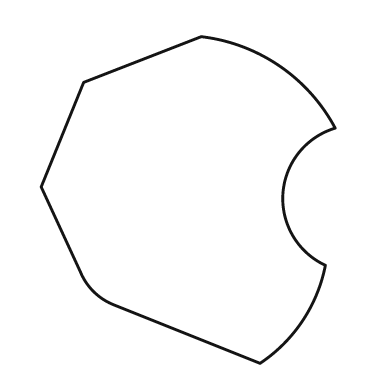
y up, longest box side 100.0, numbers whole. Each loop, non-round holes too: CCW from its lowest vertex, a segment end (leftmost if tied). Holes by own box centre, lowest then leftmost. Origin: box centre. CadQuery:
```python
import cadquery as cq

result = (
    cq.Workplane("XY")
    .moveTo(22.0, -50.0)
    .threePointArc((35.0, -37.0), (42.0, -20.0))
    .threePointArc((29.0, 2.0), (45.0, 22.0))
    .threePointArc((28.0, 41.0), (4.0, 50.0))
    .lineTo(-32.0, 36.0)
    .lineTo(-45.0, 4.0)
    .lineTo(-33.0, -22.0)
    .threePointArc((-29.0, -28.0), (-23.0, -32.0))
    .close()
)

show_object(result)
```